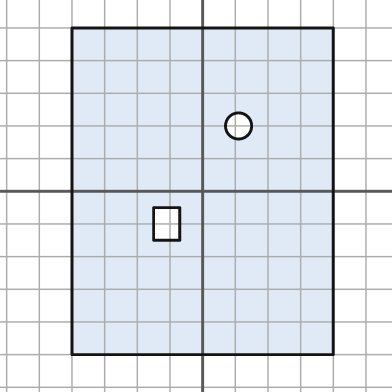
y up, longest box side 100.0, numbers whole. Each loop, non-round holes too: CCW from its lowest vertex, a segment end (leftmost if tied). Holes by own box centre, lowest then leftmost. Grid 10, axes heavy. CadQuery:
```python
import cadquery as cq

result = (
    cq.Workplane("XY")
    .moveTo(-40.0, -50.0)
    .lineTo(40.0, -50.0)
    .lineTo(40.0, 50.0)
    .lineTo(-40.0, 50.0)
    .close()
    .moveTo(-15.0, -15.0)
    .lineTo(-7.0, -15.0)
    .lineTo(-7.0, -5.0)
    .lineTo(-15.0, -5.0)
    .close()
    .moveTo(11.0, 20.0)
    .circle(4.0)
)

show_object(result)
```